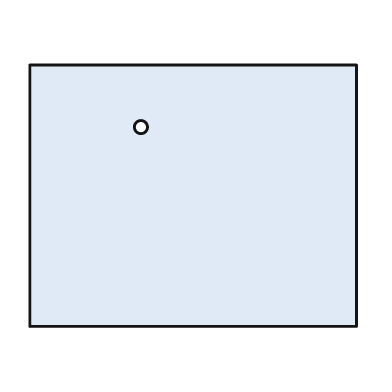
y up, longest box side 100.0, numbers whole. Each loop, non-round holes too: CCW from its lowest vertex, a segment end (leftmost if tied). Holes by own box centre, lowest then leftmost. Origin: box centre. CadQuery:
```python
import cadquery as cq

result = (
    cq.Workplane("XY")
    .moveTo(-50.0, -40.0)
    .lineTo(50.0, -40.0)
    .lineTo(50.0, 40.0)
    .lineTo(-50.0, 40.0)
    .close()
    .moveTo(-16.0, 21.0)
    .circle(2.0)
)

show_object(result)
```